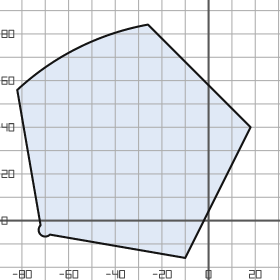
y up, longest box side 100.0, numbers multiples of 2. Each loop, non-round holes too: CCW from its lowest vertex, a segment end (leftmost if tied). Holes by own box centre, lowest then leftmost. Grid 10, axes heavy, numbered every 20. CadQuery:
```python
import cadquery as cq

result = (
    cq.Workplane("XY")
    .moveTo(-10.0, -16.0)
    .lineTo(18.0, 40.0)
    .lineTo(-26.0, 84.0)
    .threePointArc((-56.0, 74.0), (-82.0, 56.0))
    .lineTo(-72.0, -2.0)
    .threePointArc((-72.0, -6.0), (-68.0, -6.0))
    .close()
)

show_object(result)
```